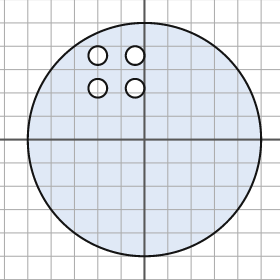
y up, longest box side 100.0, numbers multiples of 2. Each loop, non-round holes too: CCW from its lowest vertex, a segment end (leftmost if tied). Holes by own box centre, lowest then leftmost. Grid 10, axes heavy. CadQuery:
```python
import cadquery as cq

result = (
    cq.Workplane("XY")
    .moveTo(0.0, 0.0)
    .circle(50.0)
    .moveTo(-20.0, 22.0)
    .circle(4.0)
    .moveTo(-4.0, 22.0)
    .circle(4.0)
    .moveTo(-20.0, 36.0)
    .circle(4.0)
    .moveTo(-4.0, 36.0)
    .circle(4.0)
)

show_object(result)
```